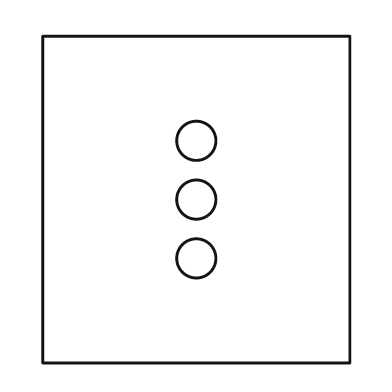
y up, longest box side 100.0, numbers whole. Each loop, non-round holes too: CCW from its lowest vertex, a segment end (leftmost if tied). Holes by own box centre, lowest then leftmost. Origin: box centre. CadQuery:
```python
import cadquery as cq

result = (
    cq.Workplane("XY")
    .moveTo(-47.0, -50.0)
    .lineTo(47.0, -50.0)
    .lineTo(47.0, 50.0)
    .lineTo(-47.0, 50.0)
    .close()
    .moveTo(0.0, -18.0)
    .circle(6.0)
    .moveTo(0.0, 0.0)
    .circle(6.0)
    .moveTo(0.0, 18.0)
    .circle(6.0)
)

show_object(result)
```